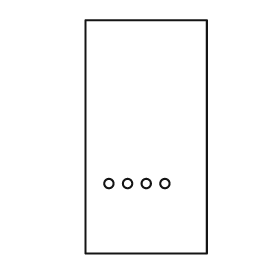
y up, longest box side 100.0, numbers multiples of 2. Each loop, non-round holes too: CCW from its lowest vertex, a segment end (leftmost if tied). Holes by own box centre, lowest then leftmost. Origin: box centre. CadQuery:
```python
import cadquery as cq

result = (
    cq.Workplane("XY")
    .moveTo(-26.0, -50.0)
    .lineTo(26.0, -50.0)
    .lineTo(26.0, 50.0)
    .lineTo(-26.0, 50.0)
    .close()
    .moveTo(-16.0, -20.0)
    .circle(2.0)
    .moveTo(-8.0, -20.0)
    .circle(2.0)
    .moveTo(0.0, -20.0)
    .circle(2.0)
    .moveTo(8.0, -20.0)
    .circle(2.0)
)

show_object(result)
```